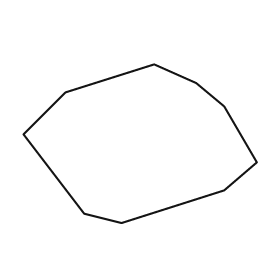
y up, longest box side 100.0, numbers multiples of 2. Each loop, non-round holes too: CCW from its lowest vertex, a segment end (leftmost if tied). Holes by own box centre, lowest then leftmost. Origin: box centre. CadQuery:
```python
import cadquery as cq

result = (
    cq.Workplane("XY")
    .moveTo(-8.0, -34.0)
    .lineTo(36.0, -20.0)
    .lineTo(50.0, -8.0)
    .lineTo(36.0, 16.0)
    .lineTo(24.0, 26.0)
    .lineTo(6.0, 34.0)
    .lineTo(-32.0, 22.0)
    .lineTo(-50.0, 4.0)
    .lineTo(-24.0, -30.0)
    .close()
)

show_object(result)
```